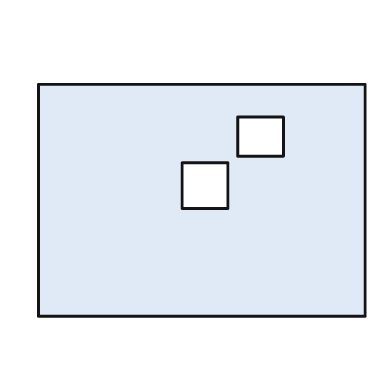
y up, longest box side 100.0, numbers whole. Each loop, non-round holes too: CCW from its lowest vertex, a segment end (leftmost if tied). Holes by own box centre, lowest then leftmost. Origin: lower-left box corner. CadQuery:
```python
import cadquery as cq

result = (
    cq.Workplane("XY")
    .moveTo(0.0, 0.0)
    .lineTo(100.0, 0.0)
    .lineTo(100.0, 71.0)
    .lineTo(0.0, 71.0)
    .close()
    .moveTo(44.0, 33.0)
    .lineTo(58.0, 33.0)
    .lineTo(58.0, 47.0)
    .lineTo(44.0, 47.0)
    .close()
    .moveTo(61.0, 49.0)
    .lineTo(75.0, 49.0)
    .lineTo(75.0, 61.0)
    .lineTo(61.0, 61.0)
    .close()
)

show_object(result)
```